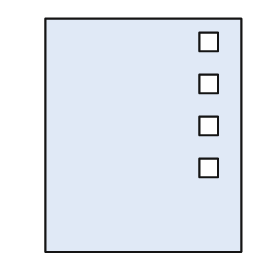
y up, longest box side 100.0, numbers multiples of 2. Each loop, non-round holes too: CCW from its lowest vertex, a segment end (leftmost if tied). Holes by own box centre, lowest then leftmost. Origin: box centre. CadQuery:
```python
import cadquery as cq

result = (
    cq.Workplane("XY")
    .moveTo(-42.0, -50.0)
    .lineTo(42.0, -50.0)
    .lineTo(42.0, 50.0)
    .lineTo(-42.0, 50.0)
    .close()
    .moveTo(24.0, -18.0)
    .lineTo(32.0, -18.0)
    .lineTo(32.0, -10.0)
    .lineTo(24.0, -10.0)
    .close()
    .moveTo(24.0, 0.0)
    .lineTo(32.0, 0.0)
    .lineTo(32.0, 8.0)
    .lineTo(24.0, 8.0)
    .close()
    .moveTo(24.0, 18.0)
    .lineTo(32.0, 18.0)
    .lineTo(32.0, 26.0)
    .lineTo(24.0, 26.0)
    .close()
    .moveTo(24.0, 36.0)
    .lineTo(32.0, 36.0)
    .lineTo(32.0, 44.0)
    .lineTo(24.0, 44.0)
    .close()
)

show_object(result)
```